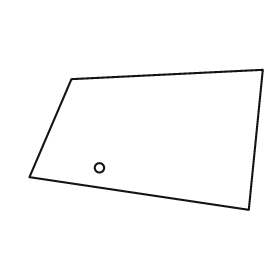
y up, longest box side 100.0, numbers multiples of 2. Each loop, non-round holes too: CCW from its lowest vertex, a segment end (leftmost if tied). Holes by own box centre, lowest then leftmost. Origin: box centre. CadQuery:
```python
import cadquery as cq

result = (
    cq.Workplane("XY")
    .moveTo(44.0, -30.0)
    .lineTo(50.0, 30.0)
    .lineTo(-32.0, 26.0)
    .lineTo(-50.0, -16.0)
    .close()
    .moveTo(-20.0, -12.0)
    .circle(2.0)
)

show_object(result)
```